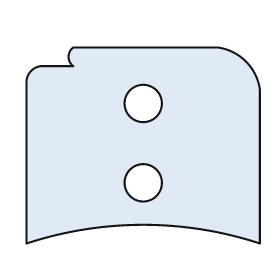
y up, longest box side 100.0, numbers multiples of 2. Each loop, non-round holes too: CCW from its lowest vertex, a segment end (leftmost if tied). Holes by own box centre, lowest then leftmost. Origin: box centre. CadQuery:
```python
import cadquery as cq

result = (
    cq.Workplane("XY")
    .moveTo(-50.0, -42.0)
    .threePointArc((0.0, -34.0), (50.0, -42.0))
    .lineTo(50.0, 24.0)
    .threePointArc((44.0, 36.0), (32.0, 42.0))
    .lineTo(-30.0, 42.0)
    .threePointArc((-32.0, 38.0), (-30.0, 34.0))
    .lineTo(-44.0, 34.0)
    .threePointArc((-48.0, 32.0), (-50.0, 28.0))
    .close()
    .moveTo(0.0, -16.0)
    .circle(8.0)
    .moveTo(0.0, 18.0)
    .circle(8.0)
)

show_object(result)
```